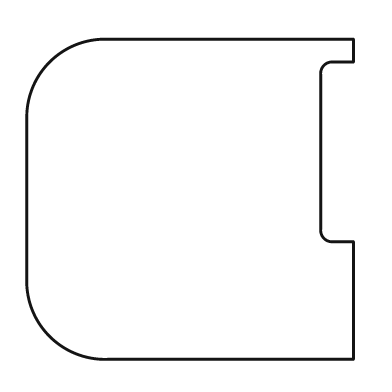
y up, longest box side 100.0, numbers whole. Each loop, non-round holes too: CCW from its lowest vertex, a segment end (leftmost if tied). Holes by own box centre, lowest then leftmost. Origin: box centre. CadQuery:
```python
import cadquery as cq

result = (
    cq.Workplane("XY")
    .moveTo(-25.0, -49.0)
    .lineTo(50.0, -49.0)
    .lineTo(50.0, -13.0)
    .lineTo(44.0, -13.0)
    .threePointArc((41.0, -12.0), (40.0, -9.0))
    .lineTo(40.0, 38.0)
    .threePointArc((41.0, 41.0), (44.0, 42.0))
    .lineTo(50.0, 42.0)
    .lineTo(50.0, 49.0)
    .lineTo(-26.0, 49.0)
    .threePointArc((-43.0, 42.0), (-50.0, 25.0))
    .lineTo(-50.0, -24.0)
    .threePointArc((-43.0, -42.0), (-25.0, -49.0))
    .close()
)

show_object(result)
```